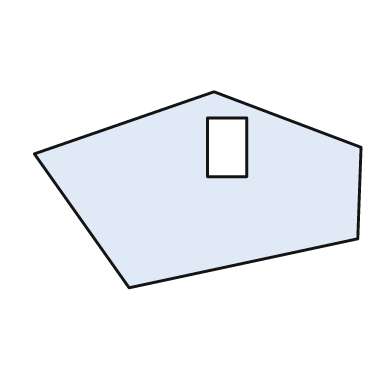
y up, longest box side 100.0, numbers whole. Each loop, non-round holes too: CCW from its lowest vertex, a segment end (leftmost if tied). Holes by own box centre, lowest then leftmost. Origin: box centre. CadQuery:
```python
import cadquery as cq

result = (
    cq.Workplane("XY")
    .moveTo(-21.0, -30.0)
    .lineTo(49.0, -15.0)
    .lineTo(50.0, 13.0)
    .lineTo(5.0, 30.0)
    .lineTo(-50.0, 11.0)
    .close()
    .moveTo(3.0, 4.0)
    .lineTo(15.0, 4.0)
    .lineTo(15.0, 22.0)
    .lineTo(3.0, 22.0)
    .close()
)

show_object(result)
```